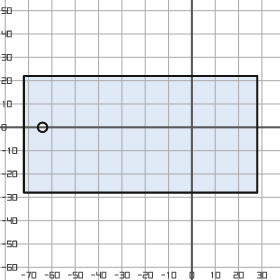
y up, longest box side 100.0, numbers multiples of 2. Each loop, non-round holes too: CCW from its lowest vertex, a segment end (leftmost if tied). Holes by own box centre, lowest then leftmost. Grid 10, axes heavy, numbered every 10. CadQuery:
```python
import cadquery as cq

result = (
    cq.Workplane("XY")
    .moveTo(-72.0, -28.0)
    .lineTo(28.0, -28.0)
    .lineTo(28.0, 22.0)
    .lineTo(-72.0, 22.0)
    .close()
    .moveTo(-64.0, 0.0)
    .circle(2.0)
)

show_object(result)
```